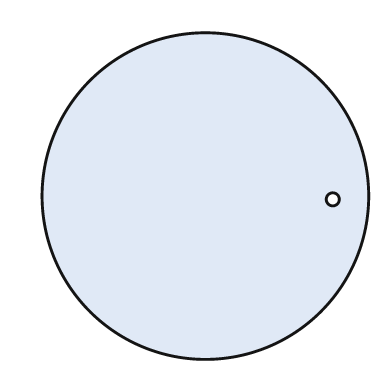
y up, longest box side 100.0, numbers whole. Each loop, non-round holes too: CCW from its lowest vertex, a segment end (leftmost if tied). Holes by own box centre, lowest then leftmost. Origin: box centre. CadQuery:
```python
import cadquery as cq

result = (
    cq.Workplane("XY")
    .moveTo(0.0, 0.0)
    .circle(50.0)
    .moveTo(39.0, -1.0)
    .circle(2.0)
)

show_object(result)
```